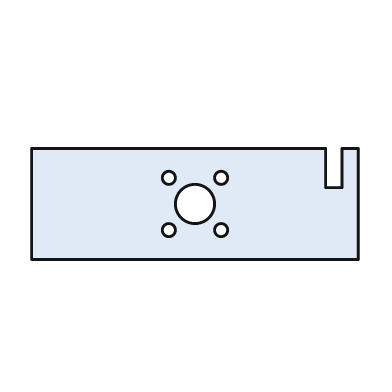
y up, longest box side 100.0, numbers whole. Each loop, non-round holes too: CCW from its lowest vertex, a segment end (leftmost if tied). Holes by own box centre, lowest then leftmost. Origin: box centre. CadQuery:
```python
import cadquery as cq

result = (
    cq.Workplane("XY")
    .moveTo(-50.0, -17.0)
    .lineTo(50.0, -17.0)
    .lineTo(50.0, 17.0)
    .lineTo(45.0, 17.0)
    .lineTo(45.0, 5.0)
    .lineTo(40.0, 5.0)
    .lineTo(40.0, 17.0)
    .lineTo(-50.0, 17.0)
    .close()
    .moveTo(-8.0, -8.0)
    .circle(2.0)
    .moveTo(8.0, -8.0)
    .circle(2.0)
    .moveTo(0.0, 0.0)
    .circle(6.0)
    .moveTo(-8.0, 8.0)
    .circle(2.0)
    .moveTo(8.0, 8.0)
    .circle(2.0)
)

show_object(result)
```